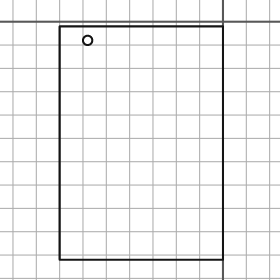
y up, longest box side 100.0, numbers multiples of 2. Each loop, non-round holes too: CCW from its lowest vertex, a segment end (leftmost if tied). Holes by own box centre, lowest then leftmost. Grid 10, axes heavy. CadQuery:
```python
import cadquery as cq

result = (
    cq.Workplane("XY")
    .moveTo(-70.0, -102.0)
    .lineTo(0.0, -102.0)
    .lineTo(0.0, -2.0)
    .lineTo(-70.0, -2.0)
    .close()
    .moveTo(-58.0, -8.0)
    .circle(2.0)
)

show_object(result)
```